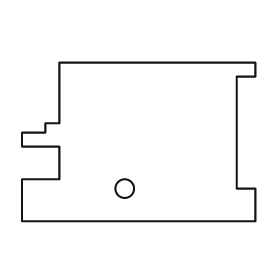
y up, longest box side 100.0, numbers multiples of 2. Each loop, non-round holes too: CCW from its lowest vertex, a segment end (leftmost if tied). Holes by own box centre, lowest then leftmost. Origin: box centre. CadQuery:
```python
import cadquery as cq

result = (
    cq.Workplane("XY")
    .moveTo(-50.0, -34.0)
    .lineTo(50.0, -34.0)
    .lineTo(50.0, -20.0)
    .lineTo(42.0, -20.0)
    .lineTo(42.0, 28.0)
    .lineTo(50.0, 28.0)
    .lineTo(50.0, 34.0)
    .lineTo(-34.0, 34.0)
    .lineTo(-34.0, 8.0)
    .lineTo(-40.0, 8.0)
    .lineTo(-40.0, 4.0)
    .lineTo(-50.0, 4.0)
    .lineTo(-50.0, -2.0)
    .lineTo(-34.0, -2.0)
    .lineTo(-34.0, -16.0)
    .lineTo(-50.0, -16.0)
    .close()
    .moveTo(-6.0, -20.0)
    .circle(4.0)
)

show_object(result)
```